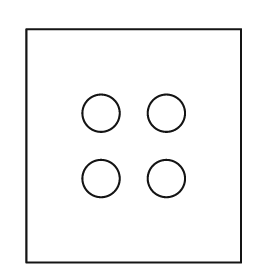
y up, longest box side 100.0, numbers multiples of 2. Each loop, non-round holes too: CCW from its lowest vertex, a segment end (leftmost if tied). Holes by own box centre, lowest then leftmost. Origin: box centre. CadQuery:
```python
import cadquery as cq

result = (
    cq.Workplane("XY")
    .moveTo(-46.0, -50.0)
    .lineTo(46.0, -50.0)
    .lineTo(46.0, 50.0)
    .lineTo(-46.0, 50.0)
    .close()
    .moveTo(-14.0, -14.0)
    .circle(8.0)
    .moveTo(14.0, -14.0)
    .circle(8.0)
    .moveTo(-14.0, 14.0)
    .circle(8.0)
    .moveTo(14.0, 14.0)
    .circle(8.0)
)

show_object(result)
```